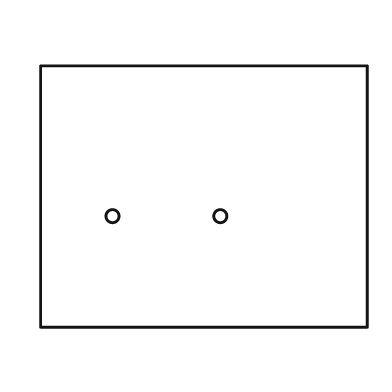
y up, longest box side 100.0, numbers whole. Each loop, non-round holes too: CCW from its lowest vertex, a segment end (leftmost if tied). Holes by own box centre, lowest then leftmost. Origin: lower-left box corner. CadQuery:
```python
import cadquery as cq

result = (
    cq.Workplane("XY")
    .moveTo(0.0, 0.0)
    .lineTo(100.0, 0.0)
    .lineTo(100.0, 80.0)
    .lineTo(0.0, 80.0)
    .close()
    .moveTo(22.0, 34.0)
    .circle(2.0)
    .moveTo(55.0, 34.0)
    .circle(2.0)
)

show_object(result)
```